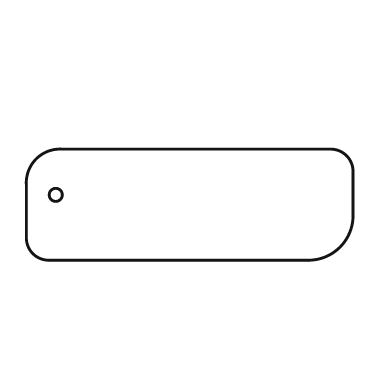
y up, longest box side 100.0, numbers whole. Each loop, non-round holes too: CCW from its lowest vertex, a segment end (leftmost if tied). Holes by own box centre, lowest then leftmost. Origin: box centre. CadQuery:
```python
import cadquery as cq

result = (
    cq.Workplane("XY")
    .moveTo(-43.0, -17.0)
    .lineTo(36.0, -17.0)
    .threePointArc((46.0, -13.0), (50.0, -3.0))
    .lineTo(50.0, 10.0)
    .threePointArc((48.0, 15.0), (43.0, 17.0))
    .lineTo(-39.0, 17.0)
    .threePointArc((-47.0, 14.0), (-50.0, 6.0))
    .lineTo(-50.0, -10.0)
    .threePointArc((-48.0, -15.0), (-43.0, -17.0))
    .close()
    .moveTo(-41.0, 3.0)
    .circle(2.0)
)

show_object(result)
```